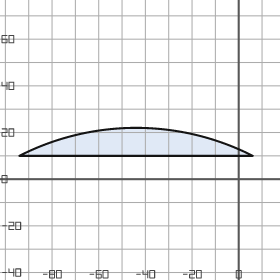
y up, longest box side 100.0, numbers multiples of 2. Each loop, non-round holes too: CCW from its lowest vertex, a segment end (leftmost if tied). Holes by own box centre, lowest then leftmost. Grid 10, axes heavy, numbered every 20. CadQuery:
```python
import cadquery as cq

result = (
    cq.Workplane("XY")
    .moveTo(-94.0, 10.0)
    .lineTo(6.0, 10.0)
    .threePointArc((-44.0, 22.0), (-94.0, 10.0))
    .close()
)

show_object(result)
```